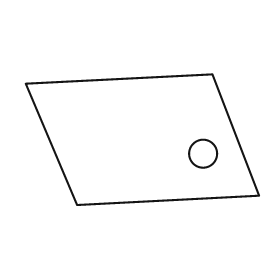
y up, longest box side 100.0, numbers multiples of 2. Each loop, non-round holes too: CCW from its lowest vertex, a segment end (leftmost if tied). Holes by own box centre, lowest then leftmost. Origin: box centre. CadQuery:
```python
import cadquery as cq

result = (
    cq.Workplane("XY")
    .moveTo(-28.0, -28.0)
    .lineTo(50.0, -24.0)
    .lineTo(30.0, 28.0)
    .lineTo(-50.0, 24.0)
    .close()
    .moveTo(26.0, -6.0)
    .circle(6.0)
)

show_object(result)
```